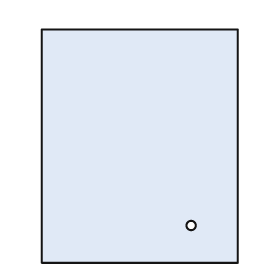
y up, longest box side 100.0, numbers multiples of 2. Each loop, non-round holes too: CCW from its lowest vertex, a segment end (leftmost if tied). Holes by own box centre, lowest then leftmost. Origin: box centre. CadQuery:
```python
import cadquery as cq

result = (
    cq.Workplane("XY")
    .moveTo(-42.0, -50.0)
    .lineTo(42.0, -50.0)
    .lineTo(42.0, 50.0)
    .lineTo(-42.0, 50.0)
    .close()
    .moveTo(22.0, -34.0)
    .circle(2.0)
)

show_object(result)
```